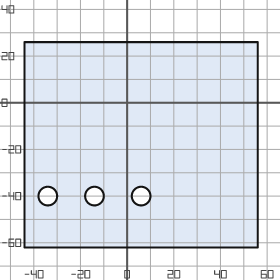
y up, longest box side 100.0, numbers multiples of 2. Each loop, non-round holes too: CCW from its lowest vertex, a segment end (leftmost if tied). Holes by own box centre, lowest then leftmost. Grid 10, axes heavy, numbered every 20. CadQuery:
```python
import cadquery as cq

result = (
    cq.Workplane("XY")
    .moveTo(-44.0, -62.0)
    .lineTo(56.0, -62.0)
    .lineTo(56.0, 26.0)
    .lineTo(-44.0, 26.0)
    .close()
    .moveTo(-34.0, -40.0)
    .circle(4.0)
    .moveTo(-14.0, -40.0)
    .circle(4.0)
    .moveTo(6.0, -40.0)
    .circle(4.0)
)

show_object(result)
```